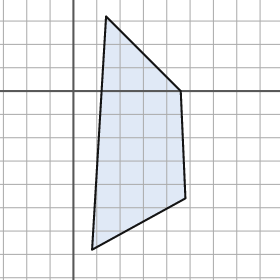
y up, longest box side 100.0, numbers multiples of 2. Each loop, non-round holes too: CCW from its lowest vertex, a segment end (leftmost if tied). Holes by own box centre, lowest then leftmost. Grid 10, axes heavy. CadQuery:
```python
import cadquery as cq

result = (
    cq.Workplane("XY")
    .moveTo(8.0, -68.0)
    .lineTo(48.0, -46.0)
    .lineTo(46.0, 0.0)
    .lineTo(14.0, 32.0)
    .close()
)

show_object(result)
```